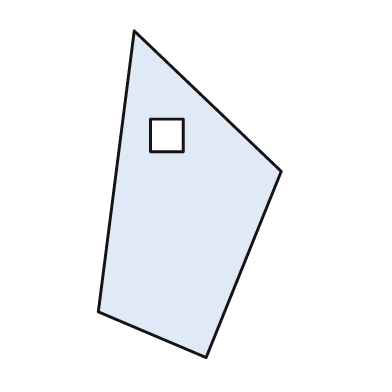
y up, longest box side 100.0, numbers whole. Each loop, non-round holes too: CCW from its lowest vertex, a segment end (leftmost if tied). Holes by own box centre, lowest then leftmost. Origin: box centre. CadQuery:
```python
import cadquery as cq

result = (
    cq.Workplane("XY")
    .moveTo(5.0, -50.0)
    .lineTo(28.0, 7.0)
    .lineTo(-17.0, 50.0)
    .lineTo(-28.0, -36.0)
    .close()
    .moveTo(-12.0, 13.0)
    .lineTo(-2.0, 13.0)
    .lineTo(-2.0, 23.0)
    .lineTo(-12.0, 23.0)
    .close()
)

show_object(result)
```